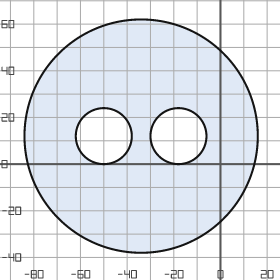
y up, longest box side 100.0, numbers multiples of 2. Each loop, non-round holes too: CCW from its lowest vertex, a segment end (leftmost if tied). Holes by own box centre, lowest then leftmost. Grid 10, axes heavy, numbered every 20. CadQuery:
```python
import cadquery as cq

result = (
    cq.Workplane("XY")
    .moveTo(-34.0, 12.0)
    .circle(50.0)
    .moveTo(-50.0, 12.0)
    .circle(12.0)
    .moveTo(-18.0, 12.0)
    .circle(12.0)
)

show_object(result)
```